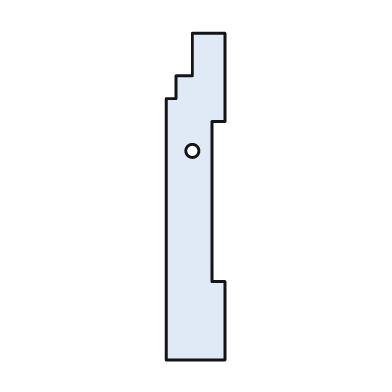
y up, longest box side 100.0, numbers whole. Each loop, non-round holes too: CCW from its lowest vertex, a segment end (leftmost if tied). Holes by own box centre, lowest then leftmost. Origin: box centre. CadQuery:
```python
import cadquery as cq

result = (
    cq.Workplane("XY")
    .moveTo(-9.0, -50.0)
    .lineTo(9.0, -50.0)
    .lineTo(9.0, -26.0)
    .lineTo(5.0, -26.0)
    .lineTo(5.0, 23.0)
    .lineTo(9.0, 23.0)
    .lineTo(9.0, 50.0)
    .lineTo(-1.0, 50.0)
    .lineTo(-1.0, 37.0)
    .lineTo(-6.0, 37.0)
    .lineTo(-6.0, 30.0)
    .lineTo(-9.0, 30.0)
    .close()
    .moveTo(-1.0, 14.0)
    .circle(2.0)
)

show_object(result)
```